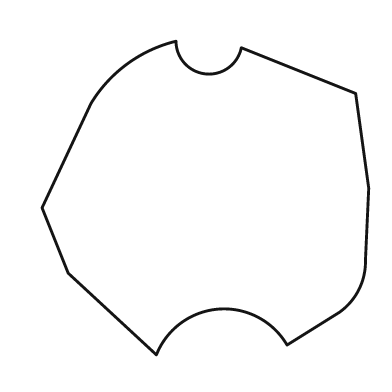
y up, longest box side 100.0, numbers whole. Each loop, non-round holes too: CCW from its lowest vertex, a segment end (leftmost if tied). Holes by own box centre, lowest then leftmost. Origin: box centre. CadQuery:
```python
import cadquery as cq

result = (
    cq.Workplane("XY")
    .moveTo(-15.0, -48.0)
    .threePointArc((4.0, -34.0), (25.0, -45.0))
    .lineTo(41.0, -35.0)
    .threePointArc((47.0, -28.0), (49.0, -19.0))
    .lineTo(50.0, 3.0)
    .lineTo(46.0, 32.0)
    .lineTo(11.0, 46.0)
    .threePointArc((0.0, 38.0), (-9.0, 48.0))
    .threePointArc((-24.0, 41.0), (-35.0, 29.0))
    .lineTo(-50.0, -3.0)
    .lineTo(-42.0, -23.0)
    .close()
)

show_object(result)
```